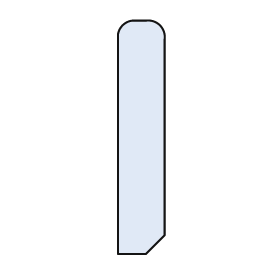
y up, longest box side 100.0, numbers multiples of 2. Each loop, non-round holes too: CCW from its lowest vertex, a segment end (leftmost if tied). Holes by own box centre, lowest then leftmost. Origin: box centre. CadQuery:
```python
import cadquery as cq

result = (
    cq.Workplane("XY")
    .moveTo(-10.0, -50.0)
    .lineTo(2.0, -50.0)
    .lineTo(10.0, -42.0)
    .lineTo(10.0, 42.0)
    .threePointArc((8.0, 48.0), (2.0, 50.0))
    .lineTo(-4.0, 50.0)
    .threePointArc((-8.0, 48.0), (-10.0, 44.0))
    .close()
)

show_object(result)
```